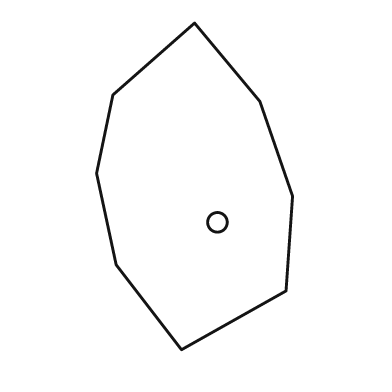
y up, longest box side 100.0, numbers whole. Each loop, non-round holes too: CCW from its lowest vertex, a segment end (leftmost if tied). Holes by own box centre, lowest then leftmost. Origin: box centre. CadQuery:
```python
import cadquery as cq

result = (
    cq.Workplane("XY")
    .moveTo(-4.0, -50.0)
    .lineTo(28.0, -32.0)
    .lineTo(30.0, -3.0)
    .lineTo(20.0, 26.0)
    .lineTo(0.0, 50.0)
    .lineTo(-25.0, 28.0)
    .lineTo(-30.0, 4.0)
    .lineTo(-24.0, -24.0)
    .close()
    .moveTo(7.0, -11.0)
    .circle(3.0)
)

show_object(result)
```